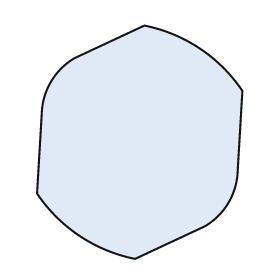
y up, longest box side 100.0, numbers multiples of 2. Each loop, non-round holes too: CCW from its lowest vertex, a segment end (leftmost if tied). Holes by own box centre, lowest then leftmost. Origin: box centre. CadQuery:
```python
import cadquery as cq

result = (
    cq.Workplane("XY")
    .moveTo(-2.0, -50.0)
    .lineTo(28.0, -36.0)
    .threePointArc((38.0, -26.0), (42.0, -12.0))
    .lineTo(44.0, 22.0)
    .threePointArc((26.0, 40.0), (2.0, 50.0))
    .lineTo(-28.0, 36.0)
    .threePointArc((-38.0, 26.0), (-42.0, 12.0))
    .lineTo(-44.0, -22.0)
    .threePointArc((-26.0, -40.0), (-2.0, -50.0))
    .close()
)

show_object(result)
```